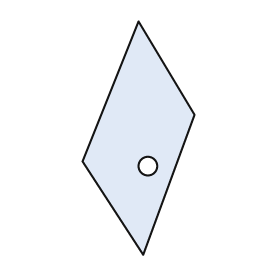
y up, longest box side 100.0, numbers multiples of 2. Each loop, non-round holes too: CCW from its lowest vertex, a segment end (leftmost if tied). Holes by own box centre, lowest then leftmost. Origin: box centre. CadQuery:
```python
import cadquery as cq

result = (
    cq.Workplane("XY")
    .moveTo(2.0, -50.0)
    .lineTo(24.0, 10.0)
    .lineTo(0.0, 50.0)
    .lineTo(-24.0, -10.0)
    .close()
    .moveTo(4.0, -12.0)
    .circle(4.0)
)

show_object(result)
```